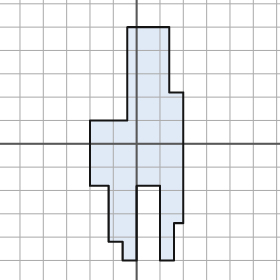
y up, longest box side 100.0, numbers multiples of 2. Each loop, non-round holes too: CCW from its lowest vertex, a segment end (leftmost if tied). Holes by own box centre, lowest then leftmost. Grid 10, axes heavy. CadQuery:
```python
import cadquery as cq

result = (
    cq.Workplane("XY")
    .moveTo(-6.0, -50.0)
    .lineTo(0.0, -50.0)
    .lineTo(0.0, -18.0)
    .lineTo(10.0, -18.0)
    .lineTo(10.0, -50.0)
    .lineTo(16.0, -50.0)
    .lineTo(16.0, -34.0)
    .lineTo(20.0, -34.0)
    .lineTo(20.0, 22.0)
    .lineTo(14.0, 22.0)
    .lineTo(14.0, 50.0)
    .lineTo(-4.0, 50.0)
    .lineTo(-4.0, 10.0)
    .lineTo(-20.0, 10.0)
    .lineTo(-20.0, -18.0)
    .lineTo(-12.0, -18.0)
    .lineTo(-12.0, -42.0)
    .lineTo(-6.0, -42.0)
    .close()
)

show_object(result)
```